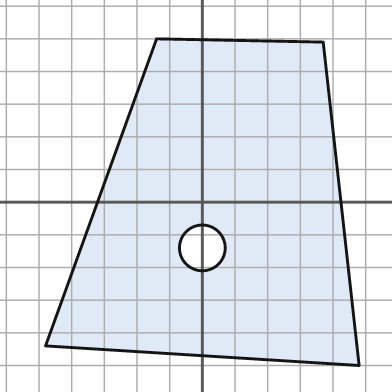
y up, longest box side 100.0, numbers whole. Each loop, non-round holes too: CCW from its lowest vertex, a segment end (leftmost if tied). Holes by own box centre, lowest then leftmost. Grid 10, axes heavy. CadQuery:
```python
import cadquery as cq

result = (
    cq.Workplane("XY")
    .moveTo(48.0, -50.0)
    .lineTo(37.0, 49.0)
    .lineTo(-14.0, 50.0)
    .lineTo(-48.0, -44.0)
    .close()
    .moveTo(0.0, -14.0)
    .circle(7.0)
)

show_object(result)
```